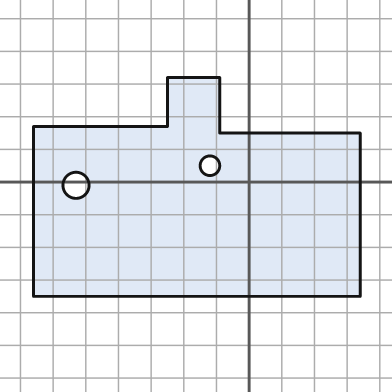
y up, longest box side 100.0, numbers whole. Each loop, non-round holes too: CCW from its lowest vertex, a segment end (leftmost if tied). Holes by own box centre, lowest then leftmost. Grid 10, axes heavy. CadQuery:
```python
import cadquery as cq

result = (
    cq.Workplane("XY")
    .moveTo(-66.0, -35.0)
    .lineTo(34.0, -35.0)
    .lineTo(34.0, 15.0)
    .lineTo(-9.0, 15.0)
    .lineTo(-9.0, 32.0)
    .lineTo(-25.0, 32.0)
    .lineTo(-25.0, 17.0)
    .lineTo(-66.0, 17.0)
    .close()
    .moveTo(-53.0, -1.0)
    .circle(4.0)
    .moveTo(-12.0, 5.0)
    .circle(3.0)
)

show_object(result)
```